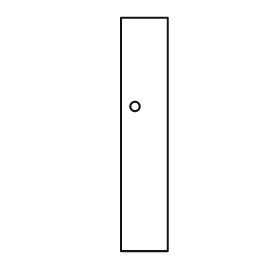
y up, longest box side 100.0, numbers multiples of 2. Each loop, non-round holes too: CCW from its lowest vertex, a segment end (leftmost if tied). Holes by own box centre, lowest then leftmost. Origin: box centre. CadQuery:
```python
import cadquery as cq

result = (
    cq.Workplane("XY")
    .moveTo(-10.0, -50.0)
    .lineTo(10.0, -50.0)
    .lineTo(10.0, 50.0)
    .lineTo(-10.0, 50.0)
    .close()
    .moveTo(-4.0, 12.0)
    .circle(2.0)
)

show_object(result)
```